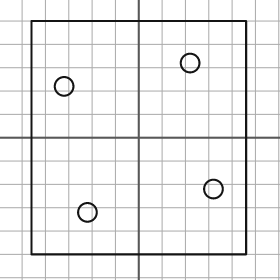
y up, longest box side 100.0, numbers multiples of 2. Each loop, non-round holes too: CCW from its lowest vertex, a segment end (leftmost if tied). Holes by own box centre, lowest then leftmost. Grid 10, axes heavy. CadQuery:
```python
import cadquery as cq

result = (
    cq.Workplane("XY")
    .moveTo(-46.0, -50.0)
    .lineTo(46.0, -50.0)
    .lineTo(46.0, 50.0)
    .lineTo(-46.0, 50.0)
    .close()
    .moveTo(-22.0, -32.0)
    .circle(4.0)
    .moveTo(32.0, -22.0)
    .circle(4.0)
    .moveTo(-32.0, 22.0)
    .circle(4.0)
    .moveTo(22.0, 32.0)
    .circle(4.0)
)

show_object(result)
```